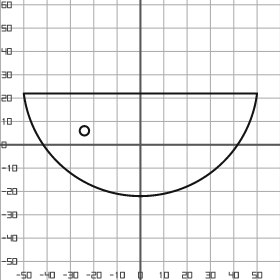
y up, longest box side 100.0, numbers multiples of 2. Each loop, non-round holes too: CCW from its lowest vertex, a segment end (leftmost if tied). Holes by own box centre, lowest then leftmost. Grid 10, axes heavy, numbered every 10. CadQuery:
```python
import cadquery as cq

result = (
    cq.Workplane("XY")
    .moveTo(-50.0, 22.0)
    .threePointArc((0.0, -22.0), (50.0, 22.0))
    .close()
    .moveTo(-24.0, 6.0)
    .circle(2.0)
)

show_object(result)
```